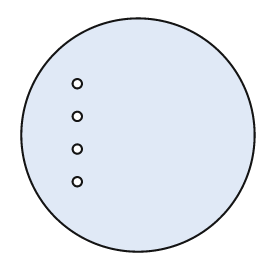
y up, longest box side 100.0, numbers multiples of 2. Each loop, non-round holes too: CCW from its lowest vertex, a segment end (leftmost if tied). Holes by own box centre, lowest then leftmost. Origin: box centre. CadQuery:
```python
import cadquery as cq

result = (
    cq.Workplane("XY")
    .moveTo(0.0, 0.0)
    .circle(50.0)
    .moveTo(-26.0, -20.0)
    .circle(2.0)
    .moveTo(-26.0, -6.0)
    .circle(2.0)
    .moveTo(-26.0, 8.0)
    .circle(2.0)
    .moveTo(-26.0, 22.0)
    .circle(2.0)
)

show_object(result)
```